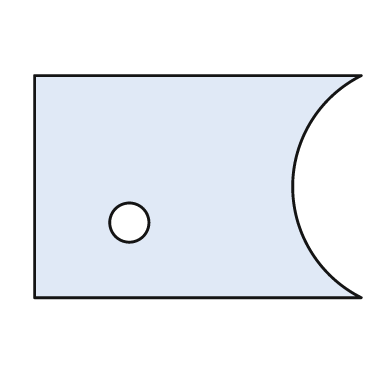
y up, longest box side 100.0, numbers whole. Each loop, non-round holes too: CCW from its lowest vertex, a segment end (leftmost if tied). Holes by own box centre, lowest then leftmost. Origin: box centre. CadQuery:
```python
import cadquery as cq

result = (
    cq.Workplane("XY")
    .moveTo(-50.0, -34.0)
    .lineTo(50.0, -34.0)
    .threePointArc((29.0, 0.0), (50.0, 34.0))
    .lineTo(-50.0, 34.0)
    .close()
    .moveTo(-21.0, -11.0)
    .circle(6.0)
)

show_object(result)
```